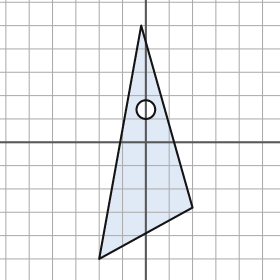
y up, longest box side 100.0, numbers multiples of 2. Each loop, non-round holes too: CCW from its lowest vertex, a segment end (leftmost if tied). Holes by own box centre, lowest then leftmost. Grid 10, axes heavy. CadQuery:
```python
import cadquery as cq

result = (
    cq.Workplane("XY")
    .moveTo(-20.0, -50.0)
    .lineTo(20.0, -28.0)
    .lineTo(-2.0, 50.0)
    .close()
    .moveTo(0.0, 14.0)
    .circle(4.0)
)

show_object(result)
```